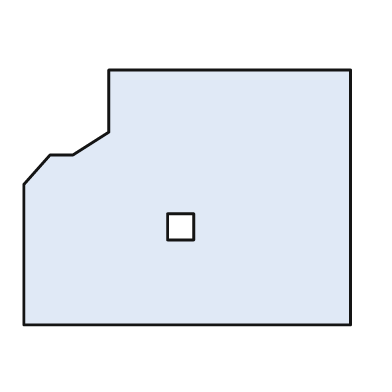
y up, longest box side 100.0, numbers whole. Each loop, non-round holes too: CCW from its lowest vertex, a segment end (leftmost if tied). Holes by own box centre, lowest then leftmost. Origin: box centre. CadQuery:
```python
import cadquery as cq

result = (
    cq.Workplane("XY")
    .moveTo(-50.0, -39.0)
    .lineTo(50.0, -39.0)
    .lineTo(50.0, 39.0)
    .lineTo(-24.0, 39.0)
    .lineTo(-24.0, 20.0)
    .lineTo(-35.0, 13.0)
    .lineTo(-42.0, 13.0)
    .lineTo(-50.0, 4.0)
    .close()
    .moveTo(-6.0, -13.0)
    .lineTo(2.0, -13.0)
    .lineTo(2.0, -5.0)
    .lineTo(-6.0, -5.0)
    .close()
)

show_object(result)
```